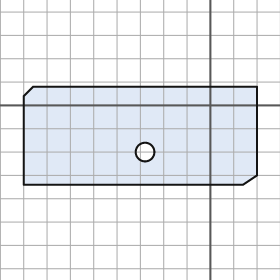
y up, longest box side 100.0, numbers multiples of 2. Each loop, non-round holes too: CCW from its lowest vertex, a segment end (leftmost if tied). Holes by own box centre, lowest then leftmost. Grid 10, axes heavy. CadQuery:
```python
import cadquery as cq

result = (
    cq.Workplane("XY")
    .moveTo(-80.0, -34.0)
    .lineTo(14.0, -34.0)
    .lineTo(20.0, -30.0)
    .lineTo(20.0, 8.0)
    .lineTo(-76.0, 8.0)
    .lineTo(-80.0, 4.0)
    .close()
    .moveTo(-28.0, -20.0)
    .circle(4.0)
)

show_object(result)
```